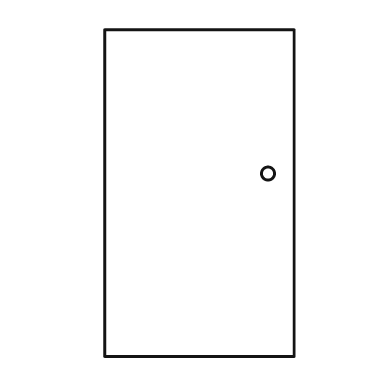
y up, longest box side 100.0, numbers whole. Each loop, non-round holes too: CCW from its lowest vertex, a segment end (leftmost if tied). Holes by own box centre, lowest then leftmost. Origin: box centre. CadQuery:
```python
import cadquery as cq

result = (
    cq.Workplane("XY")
    .moveTo(-29.0, -50.0)
    .lineTo(29.0, -50.0)
    .lineTo(29.0, 50.0)
    .lineTo(-29.0, 50.0)
    .close()
    .moveTo(21.0, 6.0)
    .circle(2.0)
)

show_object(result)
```